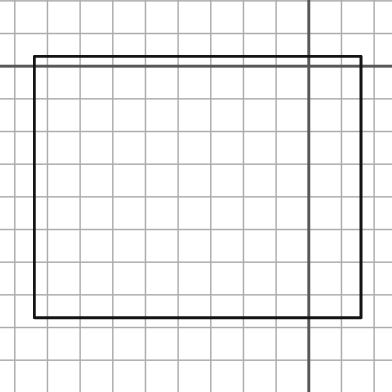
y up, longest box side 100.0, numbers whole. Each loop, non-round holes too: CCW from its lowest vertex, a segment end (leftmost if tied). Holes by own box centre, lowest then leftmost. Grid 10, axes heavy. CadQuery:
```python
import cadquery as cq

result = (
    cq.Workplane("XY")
    .moveTo(-84.0, -77.0)
    .lineTo(16.0, -77.0)
    .lineTo(16.0, 3.0)
    .lineTo(-84.0, 3.0)
    .close()
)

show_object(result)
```